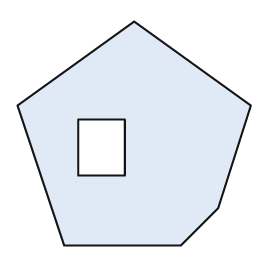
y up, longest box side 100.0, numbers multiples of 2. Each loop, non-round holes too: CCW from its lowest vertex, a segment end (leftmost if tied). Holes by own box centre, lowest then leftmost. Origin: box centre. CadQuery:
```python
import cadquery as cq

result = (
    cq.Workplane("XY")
    .moveTo(-30.0, -48.0)
    .lineTo(20.0, -48.0)
    .lineTo(36.0, -32.0)
    .lineTo(50.0, 12.0)
    .lineTo(0.0, 48.0)
    .lineTo(-50.0, 12.0)
    .close()
    .moveTo(-24.0, -18.0)
    .lineTo(-4.0, -18.0)
    .lineTo(-4.0, 6.0)
    .lineTo(-24.0, 6.0)
    .close()
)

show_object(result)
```